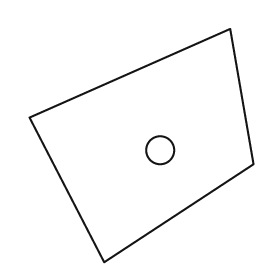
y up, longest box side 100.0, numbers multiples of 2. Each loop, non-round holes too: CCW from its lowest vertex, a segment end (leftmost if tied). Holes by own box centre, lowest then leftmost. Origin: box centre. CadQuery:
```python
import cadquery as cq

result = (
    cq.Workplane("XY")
    .moveTo(-16.0, -50.0)
    .lineTo(48.0, -8.0)
    .lineTo(38.0, 50.0)
    .lineTo(-48.0, 12.0)
    .close()
    .moveTo(8.0, -2.0)
    .circle(6.0)
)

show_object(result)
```